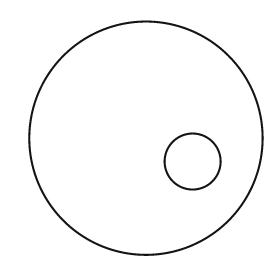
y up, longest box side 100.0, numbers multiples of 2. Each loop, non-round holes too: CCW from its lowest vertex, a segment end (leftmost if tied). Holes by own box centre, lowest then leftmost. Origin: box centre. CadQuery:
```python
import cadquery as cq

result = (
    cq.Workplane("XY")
    .moveTo(0.0, 0.0)
    .circle(50.0)
    .moveTo(20.0, -10.0)
    .circle(12.0)
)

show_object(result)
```